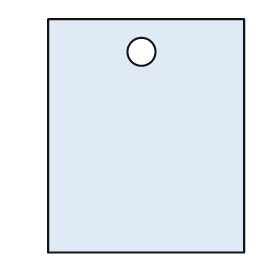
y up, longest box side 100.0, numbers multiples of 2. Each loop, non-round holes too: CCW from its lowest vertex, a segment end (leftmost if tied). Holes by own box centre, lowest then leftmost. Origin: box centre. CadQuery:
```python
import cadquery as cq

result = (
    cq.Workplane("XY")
    .moveTo(-42.0, -50.0)
    .lineTo(42.0, -50.0)
    .lineTo(42.0, 50.0)
    .lineTo(-42.0, 50.0)
    .close()
    .moveTo(-2.0, 36.0)
    .circle(6.0)
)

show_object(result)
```